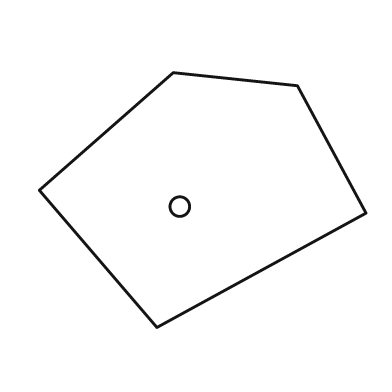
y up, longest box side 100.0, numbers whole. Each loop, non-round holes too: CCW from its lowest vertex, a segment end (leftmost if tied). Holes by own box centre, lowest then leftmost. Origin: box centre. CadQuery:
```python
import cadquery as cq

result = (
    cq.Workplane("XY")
    .moveTo(-14.0, -39.0)
    .lineTo(50.0, -4.0)
    .lineTo(29.0, 35.0)
    .lineTo(-9.0, 39.0)
    .lineTo(-50.0, 3.0)
    .close()
    .moveTo(-7.0, -2.0)
    .circle(3.0)
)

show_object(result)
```